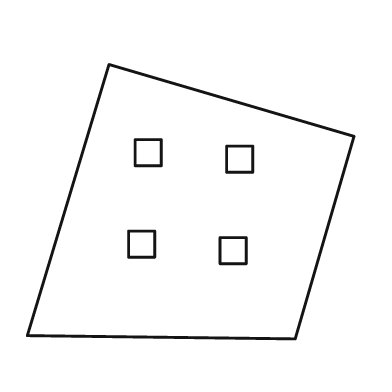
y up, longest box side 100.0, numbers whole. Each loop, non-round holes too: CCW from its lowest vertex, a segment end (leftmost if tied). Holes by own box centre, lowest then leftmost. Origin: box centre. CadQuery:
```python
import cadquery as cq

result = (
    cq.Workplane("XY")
    .moveTo(32.0, -42.0)
    .lineTo(50.0, 20.0)
    .lineTo(-25.0, 42.0)
    .lineTo(-50.0, -41.0)
    .close()
    .moveTo(9.0, -19.0)
    .lineTo(17.0, -19.0)
    .lineTo(17.0, -11.0)
    .lineTo(9.0, -11.0)
    .close()
    .moveTo(-19.0, -17.0)
    .lineTo(-11.0, -17.0)
    .lineTo(-11.0, -9.0)
    .lineTo(-19.0, -9.0)
    .close()
    .moveTo(11.0, 9.0)
    .lineTo(19.0, 9.0)
    .lineTo(19.0, 17.0)
    .lineTo(11.0, 17.0)
    .close()
    .moveTo(-17.0, 11.0)
    .lineTo(-9.0, 11.0)
    .lineTo(-9.0, 19.0)
    .lineTo(-17.0, 19.0)
    .close()
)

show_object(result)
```